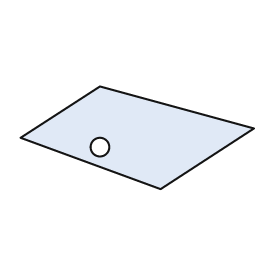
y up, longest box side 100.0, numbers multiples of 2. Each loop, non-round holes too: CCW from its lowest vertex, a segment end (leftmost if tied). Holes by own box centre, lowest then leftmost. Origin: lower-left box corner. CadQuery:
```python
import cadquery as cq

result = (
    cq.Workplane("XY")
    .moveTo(60.0, 0.0)
    .lineTo(100.0, 26.0)
    .lineTo(34.0, 44.0)
    .lineTo(0.0, 22.0)
    .close()
    .moveTo(34.0, 18.0)
    .circle(4.0)
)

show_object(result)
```